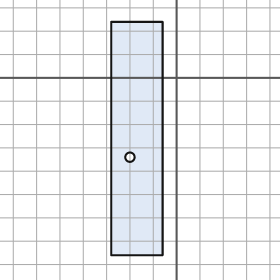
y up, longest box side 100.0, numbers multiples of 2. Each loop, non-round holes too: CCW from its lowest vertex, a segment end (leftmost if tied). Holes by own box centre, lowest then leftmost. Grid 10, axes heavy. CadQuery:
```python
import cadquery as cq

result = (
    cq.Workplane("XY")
    .moveTo(-28.0, -76.0)
    .lineTo(-6.0, -76.0)
    .lineTo(-6.0, 24.0)
    .lineTo(-28.0, 24.0)
    .close()
    .moveTo(-20.0, -34.0)
    .circle(2.0)
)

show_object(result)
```